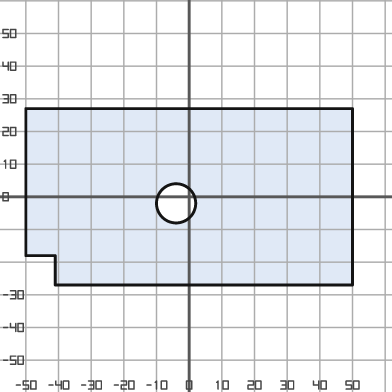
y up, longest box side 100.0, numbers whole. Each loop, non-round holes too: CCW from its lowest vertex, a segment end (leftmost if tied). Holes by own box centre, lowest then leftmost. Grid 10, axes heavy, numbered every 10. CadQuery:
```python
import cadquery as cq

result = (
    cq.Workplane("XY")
    .moveTo(-41.0, -27.0)
    .lineTo(50.0, -27.0)
    .lineTo(50.0, 27.0)
    .lineTo(-50.0, 27.0)
    .lineTo(-50.0, -18.0)
    .lineTo(-41.0, -18.0)
    .close()
    .moveTo(-4.0, -2.0)
    .circle(6.0)
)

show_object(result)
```